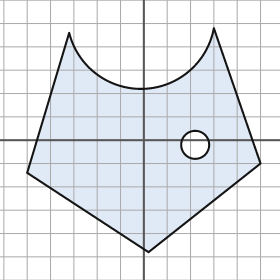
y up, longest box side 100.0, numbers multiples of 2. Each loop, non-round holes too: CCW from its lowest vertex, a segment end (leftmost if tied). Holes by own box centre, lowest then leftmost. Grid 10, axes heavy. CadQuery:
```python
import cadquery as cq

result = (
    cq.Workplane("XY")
    .moveTo(2.0, -48.0)
    .lineTo(50.0, -10.0)
    .lineTo(30.0, 48.0)
    .threePointArc((0.0, 22.0), (-32.0, 46.0))
    .lineTo(-50.0, -14.0)
    .close()
    .moveTo(22.0, -2.0)
    .circle(6.0)
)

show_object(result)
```